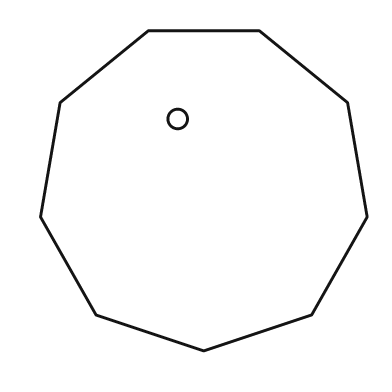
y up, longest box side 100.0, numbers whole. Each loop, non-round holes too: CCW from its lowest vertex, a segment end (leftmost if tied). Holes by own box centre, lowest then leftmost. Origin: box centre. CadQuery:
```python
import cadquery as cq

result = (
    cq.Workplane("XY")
    .moveTo(0.0, -49.0)
    .lineTo(33.0, -38.0)
    .lineTo(50.0, -8.0)
    .lineTo(44.0, 27.0)
    .lineTo(17.0, 49.0)
    .lineTo(-17.0, 49.0)
    .lineTo(-44.0, 27.0)
    .lineTo(-50.0, -8.0)
    .lineTo(-33.0, -38.0)
    .close()
    .moveTo(-8.0, 22.0)
    .circle(3.0)
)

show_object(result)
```